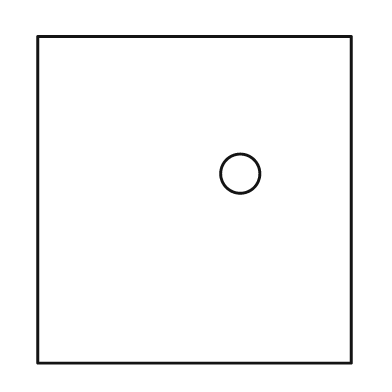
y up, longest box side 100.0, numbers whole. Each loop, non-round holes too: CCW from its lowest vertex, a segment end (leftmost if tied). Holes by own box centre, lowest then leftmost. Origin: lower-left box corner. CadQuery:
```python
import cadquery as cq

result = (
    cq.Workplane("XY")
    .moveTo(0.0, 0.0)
    .lineTo(96.0, 0.0)
    .lineTo(96.0, 100.0)
    .lineTo(0.0, 100.0)
    .close()
    .moveTo(62.0, 58.0)
    .circle(6.0)
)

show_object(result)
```